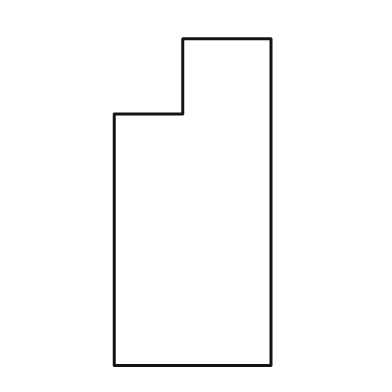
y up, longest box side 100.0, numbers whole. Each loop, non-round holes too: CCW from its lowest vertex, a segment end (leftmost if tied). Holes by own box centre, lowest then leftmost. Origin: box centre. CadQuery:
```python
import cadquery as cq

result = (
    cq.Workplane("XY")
    .moveTo(-24.0, -50.0)
    .lineTo(24.0, -50.0)
    .lineTo(24.0, 50.0)
    .lineTo(-3.0, 50.0)
    .lineTo(-3.0, 27.0)
    .lineTo(-24.0, 27.0)
    .close()
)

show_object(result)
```